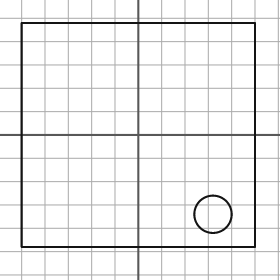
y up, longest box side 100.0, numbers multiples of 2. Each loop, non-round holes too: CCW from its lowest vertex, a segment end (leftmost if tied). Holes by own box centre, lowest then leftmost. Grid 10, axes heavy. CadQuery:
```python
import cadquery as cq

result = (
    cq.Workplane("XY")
    .moveTo(-50.0, -48.0)
    .lineTo(50.0, -48.0)
    .lineTo(50.0, 48.0)
    .lineTo(-50.0, 48.0)
    .close()
    .moveTo(32.0, -34.0)
    .circle(8.0)
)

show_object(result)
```